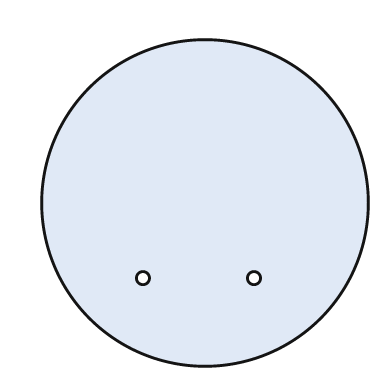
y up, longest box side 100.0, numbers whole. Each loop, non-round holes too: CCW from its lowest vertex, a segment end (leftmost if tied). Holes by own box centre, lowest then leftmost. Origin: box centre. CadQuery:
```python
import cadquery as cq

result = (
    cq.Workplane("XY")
    .moveTo(0.0, 0.0)
    .circle(50.0)
    .moveTo(-19.0, -23.0)
    .circle(2.0)
    .moveTo(15.0, -23.0)
    .circle(2.0)
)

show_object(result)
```